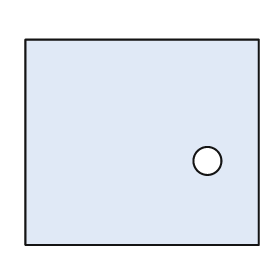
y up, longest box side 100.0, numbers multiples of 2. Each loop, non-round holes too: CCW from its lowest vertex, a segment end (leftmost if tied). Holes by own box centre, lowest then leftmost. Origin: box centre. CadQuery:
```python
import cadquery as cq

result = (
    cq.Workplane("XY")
    .moveTo(-50.0, -44.0)
    .lineTo(50.0, -44.0)
    .lineTo(50.0, 44.0)
    .lineTo(-50.0, 44.0)
    .close()
    .moveTo(28.0, -8.0)
    .circle(6.0)
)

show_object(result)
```